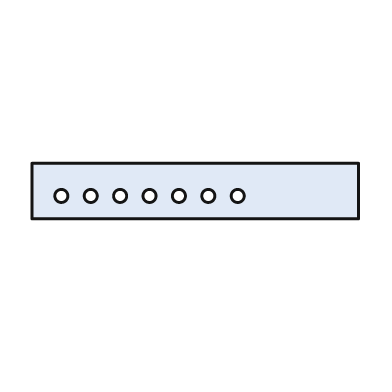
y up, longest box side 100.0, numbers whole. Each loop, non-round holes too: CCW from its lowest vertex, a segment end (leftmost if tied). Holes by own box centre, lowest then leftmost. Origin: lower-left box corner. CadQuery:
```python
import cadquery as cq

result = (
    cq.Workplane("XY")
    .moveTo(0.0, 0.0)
    .lineTo(100.0, 0.0)
    .lineTo(100.0, 17.0)
    .lineTo(0.0, 17.0)
    .close()
    .moveTo(9.0, 7.0)
    .circle(2.0)
    .moveTo(18.0, 7.0)
    .circle(2.0)
    .moveTo(27.0, 7.0)
    .circle(2.0)
    .moveTo(36.0, 7.0)
    .circle(2.0)
    .moveTo(45.0, 7.0)
    .circle(2.0)
    .moveTo(54.0, 7.0)
    .circle(2.0)
    .moveTo(63.0, 7.0)
    .circle(2.0)
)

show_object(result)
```